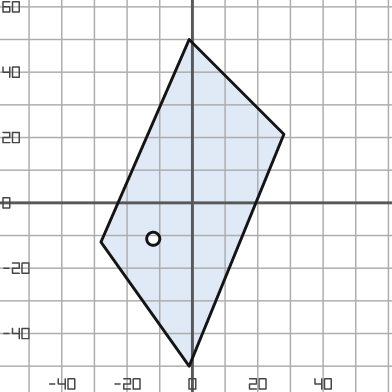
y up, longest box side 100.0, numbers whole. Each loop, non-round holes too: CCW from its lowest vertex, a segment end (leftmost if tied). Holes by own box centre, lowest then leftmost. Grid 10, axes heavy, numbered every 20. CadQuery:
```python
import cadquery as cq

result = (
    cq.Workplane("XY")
    .moveTo(-1.0, -50.0)
    .lineTo(28.0, 21.0)
    .lineTo(-1.0, 50.0)
    .lineTo(-28.0, -12.0)
    .close()
    .moveTo(-12.0, -11.0)
    .circle(2.0)
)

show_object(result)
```